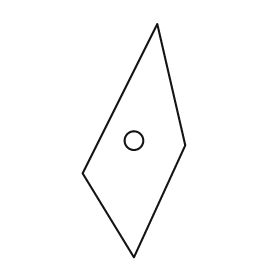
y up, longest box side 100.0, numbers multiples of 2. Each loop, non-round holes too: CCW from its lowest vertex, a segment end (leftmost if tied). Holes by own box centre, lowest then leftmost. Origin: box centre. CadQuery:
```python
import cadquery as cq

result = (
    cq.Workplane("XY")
    .moveTo(0.0, -50.0)
    .lineTo(22.0, -2.0)
    .lineTo(10.0, 50.0)
    .lineTo(-22.0, -14.0)
    .close()
    .moveTo(0.0, 0.0)
    .circle(4.0)
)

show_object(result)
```